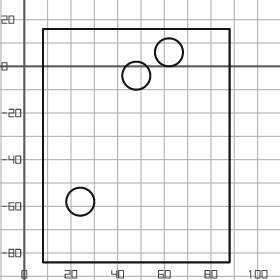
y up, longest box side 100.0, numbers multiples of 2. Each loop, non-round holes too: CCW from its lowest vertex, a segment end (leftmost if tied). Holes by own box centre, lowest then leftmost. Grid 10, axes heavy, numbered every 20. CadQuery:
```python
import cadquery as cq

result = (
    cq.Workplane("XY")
    .moveTo(8.0, -84.0)
    .lineTo(88.0, -84.0)
    .lineTo(88.0, 16.0)
    .lineTo(8.0, 16.0)
    .close()
    .moveTo(24.0, -58.0)
    .circle(6.0)
    .moveTo(48.0, -4.0)
    .circle(6.0)
    .moveTo(62.0, 6.0)
    .circle(6.0)
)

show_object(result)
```